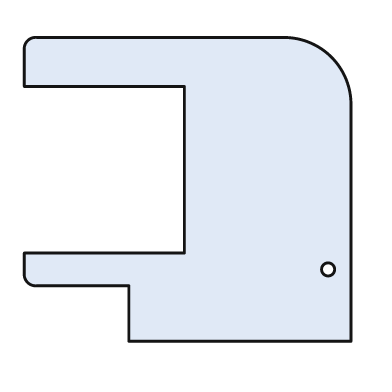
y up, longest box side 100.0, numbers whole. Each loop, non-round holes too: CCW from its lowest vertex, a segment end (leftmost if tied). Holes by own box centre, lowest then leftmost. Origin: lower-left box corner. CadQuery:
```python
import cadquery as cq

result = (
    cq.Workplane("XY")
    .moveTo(32.0, 0.0)
    .lineTo(100.0, 0.0)
    .lineTo(100.0, 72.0)
    .threePointArc((94.0, 87.0), (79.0, 93.0))
    .lineTo(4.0, 93.0)
    .threePointArc((1.0, 92.0), (0.0, 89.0))
    .lineTo(0.0, 78.0)
    .lineTo(49.0, 78.0)
    .lineTo(49.0, 27.0)
    .lineTo(0.0, 27.0)
    .lineTo(0.0, 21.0)
    .threePointArc((1.0, 18.0), (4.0, 17.0))
    .lineTo(32.0, 17.0)
    .close()
    .moveTo(93.0, 22.0)
    .circle(2.0)
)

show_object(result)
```